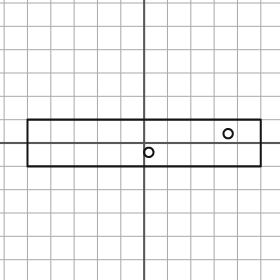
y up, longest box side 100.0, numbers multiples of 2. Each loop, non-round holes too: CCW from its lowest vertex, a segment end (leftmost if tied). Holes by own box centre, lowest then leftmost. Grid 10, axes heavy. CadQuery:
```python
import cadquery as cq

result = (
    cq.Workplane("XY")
    .moveTo(-50.0, -10.0)
    .lineTo(50.0, -10.0)
    .lineTo(50.0, 10.0)
    .lineTo(-50.0, 10.0)
    .close()
    .moveTo(2.0, -4.0)
    .circle(2.0)
    .moveTo(36.0, 4.0)
    .circle(2.0)
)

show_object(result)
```